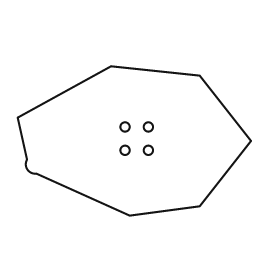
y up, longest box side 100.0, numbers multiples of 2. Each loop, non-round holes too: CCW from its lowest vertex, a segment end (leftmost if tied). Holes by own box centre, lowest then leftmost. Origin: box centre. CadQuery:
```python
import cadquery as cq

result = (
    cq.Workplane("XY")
    .moveTo(-2.0, -32.0)
    .lineTo(28.0, -28.0)
    .lineTo(50.0, 0.0)
    .lineTo(28.0, 28.0)
    .lineTo(-10.0, 32.0)
    .lineTo(-50.0, 10.0)
    .lineTo(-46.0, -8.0)
    .threePointArc((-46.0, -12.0), (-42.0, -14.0))
    .close()
    .moveTo(-4.0, -4.0)
    .circle(2.0)
    .moveTo(6.0, -4.0)
    .circle(2.0)
    .moveTo(-4.0, 6.0)
    .circle(2.0)
    .moveTo(6.0, 6.0)
    .circle(2.0)
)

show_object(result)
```